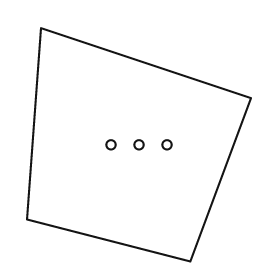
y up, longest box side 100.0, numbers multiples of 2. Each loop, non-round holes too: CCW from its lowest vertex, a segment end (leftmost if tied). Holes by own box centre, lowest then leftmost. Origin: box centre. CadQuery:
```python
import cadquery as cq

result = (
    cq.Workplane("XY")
    .moveTo(22.0, -50.0)
    .lineTo(48.0, 20.0)
    .lineTo(-42.0, 50.0)
    .lineTo(-48.0, -32.0)
    .close()
    .moveTo(-12.0, 0.0)
    .circle(2.0)
    .moveTo(0.0, 0.0)
    .circle(2.0)
    .moveTo(12.0, 0.0)
    .circle(2.0)
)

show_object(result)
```